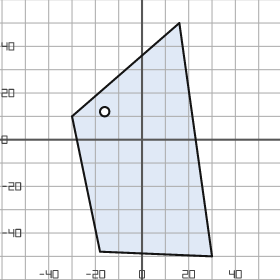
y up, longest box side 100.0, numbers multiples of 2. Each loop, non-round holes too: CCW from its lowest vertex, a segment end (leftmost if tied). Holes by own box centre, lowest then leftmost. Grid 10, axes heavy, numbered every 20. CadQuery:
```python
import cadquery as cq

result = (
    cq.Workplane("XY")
    .moveTo(30.0, -50.0)
    .lineTo(16.0, 50.0)
    .lineTo(-30.0, 10.0)
    .lineTo(-18.0, -48.0)
    .close()
    .moveTo(-16.0, 12.0)
    .circle(2.0)
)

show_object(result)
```